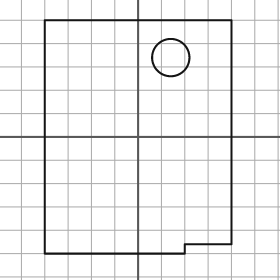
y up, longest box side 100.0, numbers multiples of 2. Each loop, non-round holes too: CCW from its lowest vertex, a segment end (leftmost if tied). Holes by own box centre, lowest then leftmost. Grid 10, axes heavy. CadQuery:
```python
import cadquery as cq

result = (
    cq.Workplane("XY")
    .moveTo(-40.0, -50.0)
    .lineTo(20.0, -50.0)
    .lineTo(20.0, -46.0)
    .lineTo(40.0, -46.0)
    .lineTo(40.0, 50.0)
    .lineTo(-40.0, 50.0)
    .close()
    .moveTo(14.0, 34.0)
    .circle(8.0)
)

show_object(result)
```